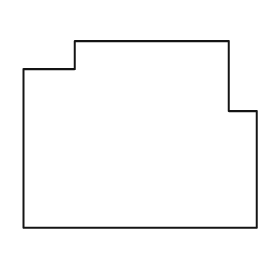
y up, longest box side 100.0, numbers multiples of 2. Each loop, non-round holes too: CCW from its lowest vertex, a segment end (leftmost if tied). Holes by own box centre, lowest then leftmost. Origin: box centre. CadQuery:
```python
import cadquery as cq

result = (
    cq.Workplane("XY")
    .moveTo(-50.0, -40.0)
    .lineTo(50.0, -40.0)
    .lineTo(50.0, 10.0)
    .lineTo(38.0, 10.0)
    .lineTo(38.0, 40.0)
    .lineTo(-28.0, 40.0)
    .lineTo(-28.0, 28.0)
    .lineTo(-50.0, 28.0)
    .close()
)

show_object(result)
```